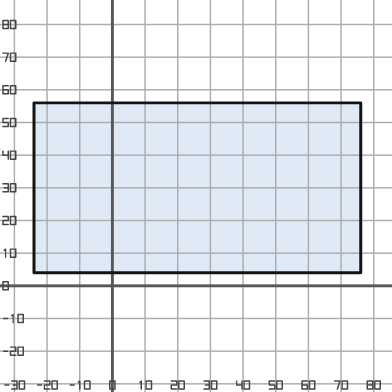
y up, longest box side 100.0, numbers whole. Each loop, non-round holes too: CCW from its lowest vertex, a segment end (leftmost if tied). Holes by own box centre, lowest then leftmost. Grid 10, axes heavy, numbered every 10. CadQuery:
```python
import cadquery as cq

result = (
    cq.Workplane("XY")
    .moveTo(-24.0, 4.0)
    .lineTo(76.0, 4.0)
    .lineTo(76.0, 56.0)
    .lineTo(-24.0, 56.0)
    .close()
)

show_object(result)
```